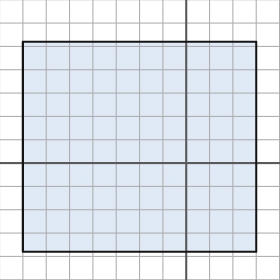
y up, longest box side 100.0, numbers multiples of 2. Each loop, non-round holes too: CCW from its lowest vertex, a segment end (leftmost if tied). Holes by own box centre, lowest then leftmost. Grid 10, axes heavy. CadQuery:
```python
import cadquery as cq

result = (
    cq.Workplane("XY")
    .moveTo(-70.0, -38.0)
    .lineTo(30.0, -38.0)
    .lineTo(30.0, 52.0)
    .lineTo(-70.0, 52.0)
    .close()
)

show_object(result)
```